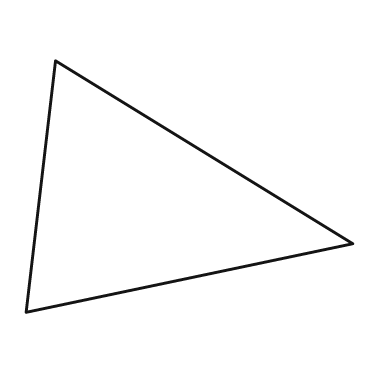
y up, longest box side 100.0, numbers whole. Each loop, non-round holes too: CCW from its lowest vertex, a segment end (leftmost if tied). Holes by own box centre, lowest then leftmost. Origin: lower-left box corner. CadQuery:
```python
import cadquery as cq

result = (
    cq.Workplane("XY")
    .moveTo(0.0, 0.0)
    .lineTo(100.0, 21.0)
    .lineTo(9.0, 77.0)
    .close()
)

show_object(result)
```